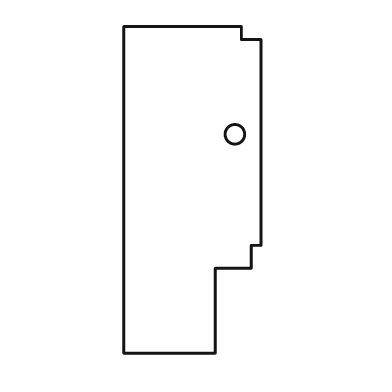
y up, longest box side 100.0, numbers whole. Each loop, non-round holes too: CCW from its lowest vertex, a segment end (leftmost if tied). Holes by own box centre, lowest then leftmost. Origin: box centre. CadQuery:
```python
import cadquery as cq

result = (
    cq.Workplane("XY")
    .moveTo(-21.0, -50.0)
    .lineTo(7.0, -50.0)
    .lineTo(7.0, -24.0)
    .lineTo(18.0, -24.0)
    .lineTo(18.0, -17.0)
    .lineTo(21.0, -17.0)
    .lineTo(21.0, 46.0)
    .lineTo(15.0, 46.0)
    .lineTo(15.0, 50.0)
    .lineTo(-21.0, 50.0)
    .close()
    .moveTo(13.0, 17.0)
    .circle(3.0)
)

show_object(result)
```